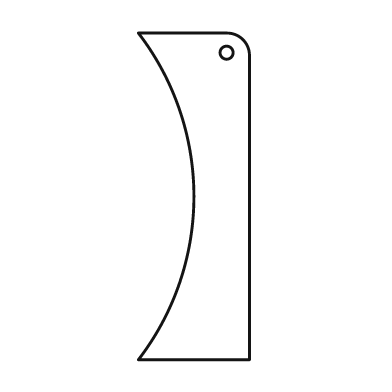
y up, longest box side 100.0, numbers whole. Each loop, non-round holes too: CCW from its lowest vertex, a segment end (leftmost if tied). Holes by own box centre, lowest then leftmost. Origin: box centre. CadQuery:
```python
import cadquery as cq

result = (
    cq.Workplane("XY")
    .moveTo(-17.0, -50.0)
    .lineTo(17.0, -50.0)
    .lineTo(17.0, 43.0)
    .threePointArc((15.0, 48.0), (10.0, 50.0))
    .lineTo(-17.0, 50.0)
    .threePointArc((0.0, 0.0), (-17.0, -50.0))
    .close()
    .moveTo(10.0, 44.0)
    .circle(2.0)
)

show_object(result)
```